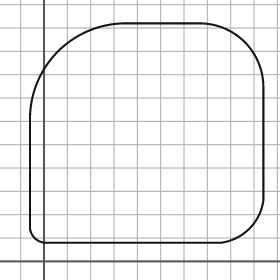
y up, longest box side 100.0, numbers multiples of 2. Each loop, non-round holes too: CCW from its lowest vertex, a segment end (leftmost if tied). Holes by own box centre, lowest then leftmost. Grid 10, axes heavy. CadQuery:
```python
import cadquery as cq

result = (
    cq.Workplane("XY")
    .moveTo(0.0, 8.0)
    .lineTo(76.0, 8.0)
    .threePointArc((88.0, 14.0), (94.0, 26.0))
    .lineTo(94.0, 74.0)
    .threePointArc((86.0, 94.0), (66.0, 102.0))
    .lineTo(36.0, 102.0)
    .threePointArc((6.0, 90.0), (-6.0, 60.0))
    .lineTo(-6.0, 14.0)
    .threePointArc((-4.0, 10.0), (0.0, 8.0))
    .close()
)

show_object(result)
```